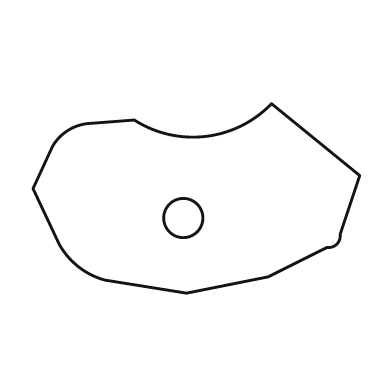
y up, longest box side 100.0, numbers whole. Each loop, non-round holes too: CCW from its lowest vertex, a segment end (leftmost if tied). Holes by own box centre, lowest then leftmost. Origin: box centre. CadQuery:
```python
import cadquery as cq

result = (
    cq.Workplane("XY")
    .moveTo(-3.0, -29.0)
    .lineTo(22.0, -24.0)
    .lineTo(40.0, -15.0)
    .threePointArc((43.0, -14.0), (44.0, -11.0))
    .lineTo(50.0, 7.0)
    .lineTo(23.0, 29.0)
    .threePointArc((3.0, 19.0), (-19.0, 24.0))
    .lineTo(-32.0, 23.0)
    .threePointArc((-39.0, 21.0), (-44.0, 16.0))
    .lineTo(-50.0, 3.0)
    .lineTo(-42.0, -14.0)
    .threePointArc((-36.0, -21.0), (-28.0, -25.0))
    .close()
    .moveTo(-4.0, -6.0)
    .circle(6.0)
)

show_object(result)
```